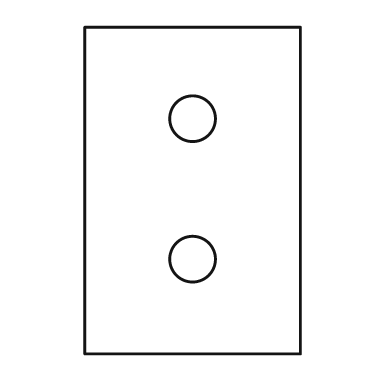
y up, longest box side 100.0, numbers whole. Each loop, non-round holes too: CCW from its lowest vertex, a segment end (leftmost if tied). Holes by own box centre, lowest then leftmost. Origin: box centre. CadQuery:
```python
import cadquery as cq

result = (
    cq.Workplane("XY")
    .moveTo(-33.0, -50.0)
    .lineTo(33.0, -50.0)
    .lineTo(33.0, 50.0)
    .lineTo(-33.0, 50.0)
    .close()
    .moveTo(0.0, -21.0)
    .circle(7.0)
    .moveTo(0.0, 22.0)
    .circle(7.0)
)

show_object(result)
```